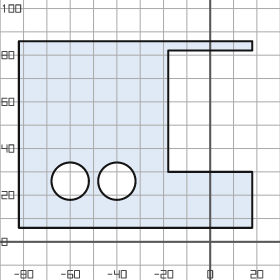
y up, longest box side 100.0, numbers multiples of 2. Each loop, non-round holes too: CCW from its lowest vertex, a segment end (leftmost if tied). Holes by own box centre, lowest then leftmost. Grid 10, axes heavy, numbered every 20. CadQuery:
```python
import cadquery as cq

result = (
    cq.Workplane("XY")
    .moveTo(-82.0, 6.0)
    .lineTo(18.0, 6.0)
    .lineTo(18.0, 30.0)
    .lineTo(-18.0, 30.0)
    .lineTo(-18.0, 82.0)
    .lineTo(18.0, 82.0)
    .lineTo(18.0, 86.0)
    .lineTo(-82.0, 86.0)
    .close()
    .moveTo(-60.0, 26.0)
    .circle(8.0)
    .moveTo(-40.0, 26.0)
    .circle(8.0)
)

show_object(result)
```